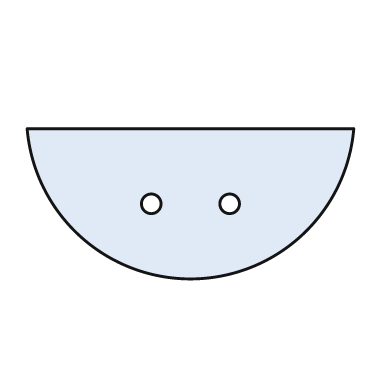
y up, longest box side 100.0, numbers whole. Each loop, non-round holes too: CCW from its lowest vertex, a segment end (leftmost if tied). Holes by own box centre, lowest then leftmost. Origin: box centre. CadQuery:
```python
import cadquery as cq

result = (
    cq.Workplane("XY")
    .moveTo(-50.0, 23.0)
    .threePointArc((0.0, -23.0), (50.0, 23.0))
    .close()
    .moveTo(-12.0, 0.0)
    .circle(3.0)
    .moveTo(12.0, 0.0)
    .circle(3.0)
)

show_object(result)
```